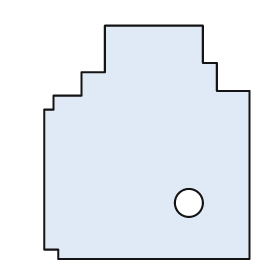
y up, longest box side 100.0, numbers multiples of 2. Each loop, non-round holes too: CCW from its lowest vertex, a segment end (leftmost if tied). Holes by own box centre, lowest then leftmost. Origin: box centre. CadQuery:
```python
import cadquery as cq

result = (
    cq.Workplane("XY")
    .moveTo(-38.0, -50.0)
    .lineTo(44.0, -50.0)
    .lineTo(44.0, 22.0)
    .lineTo(30.0, 22.0)
    .lineTo(30.0, 34.0)
    .lineTo(24.0, 34.0)
    .lineTo(24.0, 50.0)
    .lineTo(-18.0, 50.0)
    .lineTo(-18.0, 30.0)
    .lineTo(-28.0, 30.0)
    .lineTo(-28.0, 20.0)
    .lineTo(-40.0, 20.0)
    .lineTo(-40.0, 14.0)
    .lineTo(-44.0, 14.0)
    .lineTo(-44.0, -46.0)
    .lineTo(-38.0, -46.0)
    .close()
    .moveTo(18.0, -26.0)
    .circle(6.0)
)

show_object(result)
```